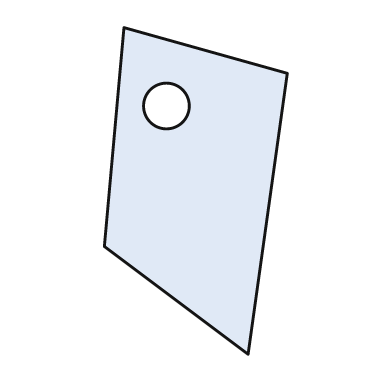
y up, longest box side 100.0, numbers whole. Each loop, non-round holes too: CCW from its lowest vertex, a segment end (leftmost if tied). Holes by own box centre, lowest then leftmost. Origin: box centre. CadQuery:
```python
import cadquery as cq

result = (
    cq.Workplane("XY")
    .moveTo(16.0, -50.0)
    .lineTo(28.0, 36.0)
    .lineTo(-22.0, 50.0)
    .lineTo(-28.0, -17.0)
    .close()
    .moveTo(-9.0, 26.0)
    .circle(7.0)
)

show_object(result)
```